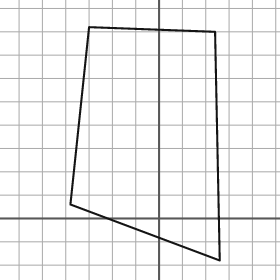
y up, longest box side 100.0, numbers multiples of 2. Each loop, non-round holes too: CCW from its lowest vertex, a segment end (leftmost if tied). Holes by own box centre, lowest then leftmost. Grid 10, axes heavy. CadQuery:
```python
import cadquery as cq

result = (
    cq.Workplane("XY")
    .moveTo(26.0, -18.0)
    .lineTo(24.0, 80.0)
    .lineTo(-30.0, 82.0)
    .lineTo(-38.0, 6.0)
    .close()
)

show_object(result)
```